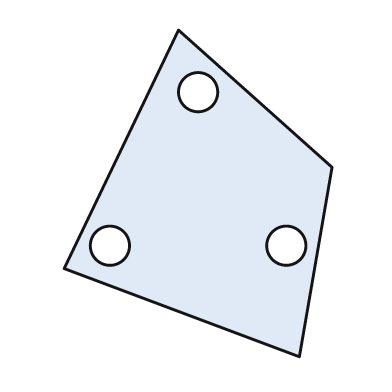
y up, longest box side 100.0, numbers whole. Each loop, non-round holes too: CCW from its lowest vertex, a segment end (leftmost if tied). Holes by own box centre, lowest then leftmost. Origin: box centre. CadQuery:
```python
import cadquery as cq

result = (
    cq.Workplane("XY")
    .moveTo(31.0, -50.0)
    .lineTo(41.0, 8.0)
    .lineTo(-6.0, 50.0)
    .lineTo(-41.0, -23.0)
    .close()
    .moveTo(-27.0, -16.0)
    .circle(6.0)
    .moveTo(27.0, -16.0)
    .circle(6.0)
    .moveTo(0.0, 31.0)
    .circle(6.0)
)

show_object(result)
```